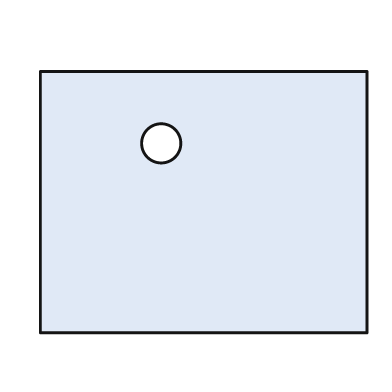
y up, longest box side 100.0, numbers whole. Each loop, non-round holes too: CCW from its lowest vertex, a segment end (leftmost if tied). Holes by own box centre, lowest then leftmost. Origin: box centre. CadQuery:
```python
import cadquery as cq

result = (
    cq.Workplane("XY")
    .moveTo(-50.0, -40.0)
    .lineTo(50.0, -40.0)
    .lineTo(50.0, 40.0)
    .lineTo(-50.0, 40.0)
    .close()
    .moveTo(-13.0, 18.0)
    .circle(6.0)
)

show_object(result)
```